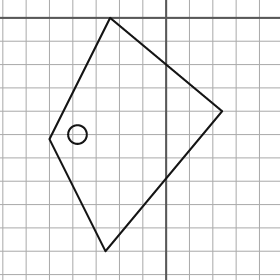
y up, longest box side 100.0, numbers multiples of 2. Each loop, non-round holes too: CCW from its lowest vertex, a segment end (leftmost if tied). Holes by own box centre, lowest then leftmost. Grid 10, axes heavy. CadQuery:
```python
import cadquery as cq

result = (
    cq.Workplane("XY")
    .moveTo(-26.0, -100.0)
    .lineTo(24.0, -40.0)
    .lineTo(-24.0, 0.0)
    .lineTo(-50.0, -52.0)
    .close()
    .moveTo(-38.0, -50.0)
    .circle(4.0)
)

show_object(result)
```